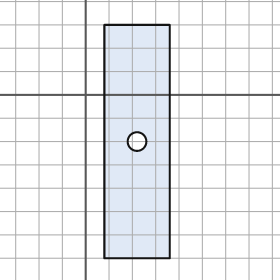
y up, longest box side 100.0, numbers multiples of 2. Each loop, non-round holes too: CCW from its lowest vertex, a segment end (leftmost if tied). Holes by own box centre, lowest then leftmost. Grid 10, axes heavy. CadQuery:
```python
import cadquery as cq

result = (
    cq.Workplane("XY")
    .moveTo(8.0, -70.0)
    .lineTo(36.0, -70.0)
    .lineTo(36.0, 30.0)
    .lineTo(8.0, 30.0)
    .close()
    .moveTo(22.0, -20.0)
    .circle(4.0)
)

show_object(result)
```